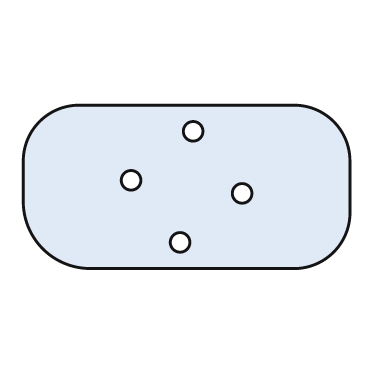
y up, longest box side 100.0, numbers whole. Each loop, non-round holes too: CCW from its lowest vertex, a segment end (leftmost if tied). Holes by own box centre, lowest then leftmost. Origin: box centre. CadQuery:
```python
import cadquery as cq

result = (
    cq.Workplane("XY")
    .moveTo(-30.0, -25.0)
    .lineTo(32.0, -25.0)
    .threePointArc((45.0, -20.0), (50.0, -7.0))
    .lineTo(50.0, 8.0)
    .threePointArc((45.0, 20.0), (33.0, 25.0))
    .lineTo(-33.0, 25.0)
    .threePointArc((-45.0, 20.0), (-50.0, 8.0))
    .lineTo(-50.0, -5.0)
    .threePointArc((-44.0, -19.0), (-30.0, -25.0))
    .close()
    .moveTo(-2.0, -17.0)
    .circle(3.0)
    .moveTo(17.0, -2.0)
    .circle(3.0)
    .moveTo(-17.0, 2.0)
    .circle(3.0)
    .moveTo(2.0, 17.0)
    .circle(3.0)
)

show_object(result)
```